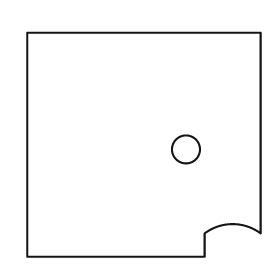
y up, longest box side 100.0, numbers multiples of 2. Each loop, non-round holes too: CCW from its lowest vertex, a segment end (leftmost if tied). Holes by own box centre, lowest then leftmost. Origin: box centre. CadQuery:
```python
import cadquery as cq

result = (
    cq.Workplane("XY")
    .moveTo(-50.0, -48.0)
    .lineTo(26.0, -48.0)
    .lineTo(26.0, -38.0)
    .threePointArc((38.0, -34.0), (50.0, -38.0))
    .lineTo(50.0, 48.0)
    .lineTo(-50.0, 48.0)
    .close()
    .moveTo(18.0, -2.0)
    .circle(6.0)
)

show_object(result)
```